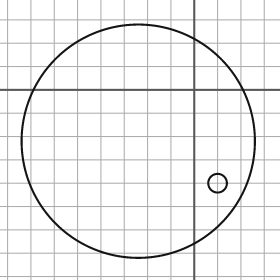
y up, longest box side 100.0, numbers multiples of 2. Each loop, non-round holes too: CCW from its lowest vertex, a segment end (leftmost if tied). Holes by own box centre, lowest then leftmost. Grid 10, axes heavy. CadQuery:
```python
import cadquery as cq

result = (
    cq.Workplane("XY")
    .moveTo(-24.0, -22.0)
    .circle(50.0)
    .moveTo(10.0, -40.0)
    .circle(4.0)
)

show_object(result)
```